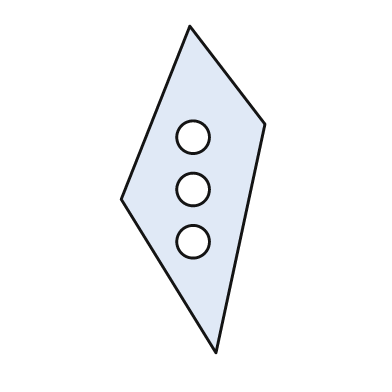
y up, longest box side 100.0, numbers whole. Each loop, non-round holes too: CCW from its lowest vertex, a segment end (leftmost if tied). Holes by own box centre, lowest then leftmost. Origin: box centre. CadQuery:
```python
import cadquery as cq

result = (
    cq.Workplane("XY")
    .moveTo(7.0, -50.0)
    .lineTo(22.0, 20.0)
    .lineTo(-1.0, 50.0)
    .lineTo(-22.0, -3.0)
    .close()
    .moveTo(0.0, -16.0)
    .circle(5.0)
    .moveTo(0.0, 0.0)
    .circle(5.0)
    .moveTo(0.0, 16.0)
    .circle(5.0)
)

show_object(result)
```